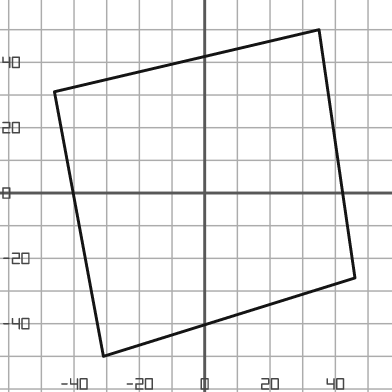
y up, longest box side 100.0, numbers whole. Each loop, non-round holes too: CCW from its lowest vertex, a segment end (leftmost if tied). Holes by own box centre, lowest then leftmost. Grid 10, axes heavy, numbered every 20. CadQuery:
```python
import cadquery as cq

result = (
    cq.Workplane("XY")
    .moveTo(-31.0, -50.0)
    .lineTo(46.0, -26.0)
    .lineTo(35.0, 50.0)
    .lineTo(-46.0, 31.0)
    .close()
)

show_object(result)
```